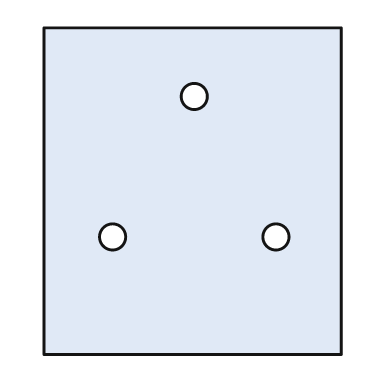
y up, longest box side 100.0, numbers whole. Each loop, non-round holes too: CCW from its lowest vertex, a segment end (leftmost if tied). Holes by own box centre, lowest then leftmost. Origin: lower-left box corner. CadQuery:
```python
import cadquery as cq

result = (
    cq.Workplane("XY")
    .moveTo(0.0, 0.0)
    .lineTo(91.0, 0.0)
    .lineTo(91.0, 100.0)
    .lineTo(0.0, 100.0)
    .close()
    .moveTo(21.0, 36.0)
    .circle(4.0)
    .moveTo(71.0, 36.0)
    .circle(4.0)
    .moveTo(46.0, 79.0)
    .circle(4.0)
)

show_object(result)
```